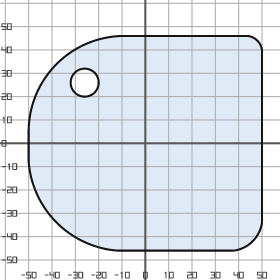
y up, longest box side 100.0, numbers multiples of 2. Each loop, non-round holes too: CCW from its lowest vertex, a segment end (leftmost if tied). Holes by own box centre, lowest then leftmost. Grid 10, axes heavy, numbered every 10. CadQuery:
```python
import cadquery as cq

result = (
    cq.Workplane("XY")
    .moveTo(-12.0, -46.0)
    .lineTo(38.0, -46.0)
    .threePointArc((46.0, -42.0), (50.0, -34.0))
    .lineTo(50.0, 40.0)
    .threePointArc((48.0, 44.0), (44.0, 46.0))
    .lineTo(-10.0, 46.0)
    .threePointArc((-38.0, 34.0), (-50.0, 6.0))
    .lineTo(-50.0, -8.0)
    .threePointArc((-38.0, -34.0), (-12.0, -46.0))
    .close()
    .moveTo(-26.0, 26.0)
    .circle(6.0)
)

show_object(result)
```